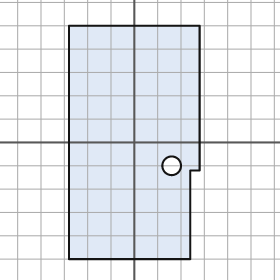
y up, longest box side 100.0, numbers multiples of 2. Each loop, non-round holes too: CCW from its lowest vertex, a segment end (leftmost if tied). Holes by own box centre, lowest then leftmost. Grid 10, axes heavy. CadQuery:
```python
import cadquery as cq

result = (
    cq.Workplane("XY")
    .moveTo(-28.0, -50.0)
    .lineTo(24.0, -50.0)
    .lineTo(24.0, -12.0)
    .lineTo(28.0, -12.0)
    .lineTo(28.0, 50.0)
    .lineTo(-28.0, 50.0)
    .close()
    .moveTo(16.0, -10.0)
    .circle(4.0)
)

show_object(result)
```